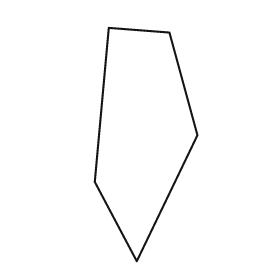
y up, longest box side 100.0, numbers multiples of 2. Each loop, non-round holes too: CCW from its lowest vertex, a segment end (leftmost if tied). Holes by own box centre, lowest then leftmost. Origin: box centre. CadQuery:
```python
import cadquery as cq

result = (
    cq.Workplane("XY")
    .moveTo(-4.0, -50.0)
    .lineTo(22.0, 4.0)
    .lineTo(10.0, 48.0)
    .lineTo(-16.0, 50.0)
    .lineTo(-22.0, -16.0)
    .close()
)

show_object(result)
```